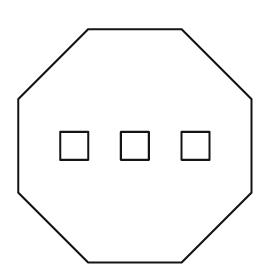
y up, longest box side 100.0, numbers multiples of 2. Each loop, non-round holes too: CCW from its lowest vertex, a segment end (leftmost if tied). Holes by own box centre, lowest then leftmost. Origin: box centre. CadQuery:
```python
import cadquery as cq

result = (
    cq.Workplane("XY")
    .moveTo(-20.0, -50.0)
    .lineTo(20.0, -50.0)
    .lineTo(50.0, -20.0)
    .lineTo(50.0, 20.0)
    .lineTo(20.0, 50.0)
    .lineTo(-20.0, 50.0)
    .lineTo(-50.0, 20.0)
    .lineTo(-50.0, -20.0)
    .close()
    .moveTo(-32.0, -6.0)
    .lineTo(-20.0, -6.0)
    .lineTo(-20.0, 6.0)
    .lineTo(-32.0, 6.0)
    .close()
    .moveTo(-6.0, -6.0)
    .lineTo(6.0, -6.0)
    .lineTo(6.0, 6.0)
    .lineTo(-6.0, 6.0)
    .close()
    .moveTo(20.0, -6.0)
    .lineTo(32.0, -6.0)
    .lineTo(32.0, 6.0)
    .lineTo(20.0, 6.0)
    .close()
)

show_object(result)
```